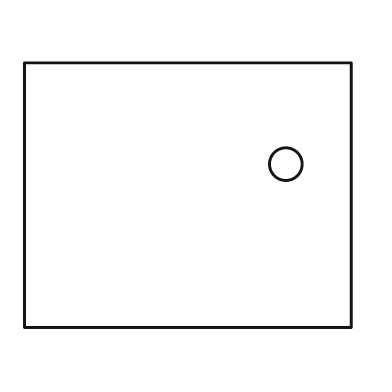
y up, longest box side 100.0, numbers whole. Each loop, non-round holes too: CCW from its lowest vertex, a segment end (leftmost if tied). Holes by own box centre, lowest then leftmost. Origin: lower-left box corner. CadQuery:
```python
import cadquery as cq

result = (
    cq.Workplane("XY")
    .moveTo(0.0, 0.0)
    .lineTo(100.0, 0.0)
    .lineTo(100.0, 81.0)
    .lineTo(0.0, 81.0)
    .close()
    .moveTo(80.0, 50.0)
    .circle(5.0)
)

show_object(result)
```